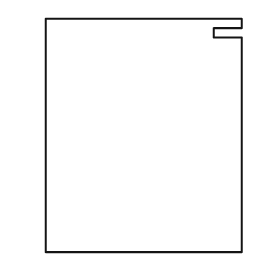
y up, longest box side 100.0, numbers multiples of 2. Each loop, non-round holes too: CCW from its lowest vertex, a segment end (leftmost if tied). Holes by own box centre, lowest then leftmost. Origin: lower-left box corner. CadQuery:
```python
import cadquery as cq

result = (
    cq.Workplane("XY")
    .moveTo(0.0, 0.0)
    .lineTo(84.0, 0.0)
    .lineTo(84.0, 92.0)
    .lineTo(72.0, 92.0)
    .lineTo(72.0, 96.0)
    .lineTo(84.0, 96.0)
    .lineTo(84.0, 100.0)
    .lineTo(0.0, 100.0)
    .close()
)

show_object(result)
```